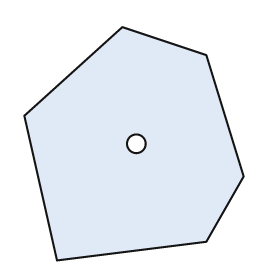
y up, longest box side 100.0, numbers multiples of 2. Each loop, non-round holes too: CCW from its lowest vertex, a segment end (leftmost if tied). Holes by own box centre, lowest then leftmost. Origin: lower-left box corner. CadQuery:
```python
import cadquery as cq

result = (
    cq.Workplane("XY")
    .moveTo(14.0, 0.0)
    .lineTo(78.0, 8.0)
    .lineTo(94.0, 36.0)
    .lineTo(78.0, 88.0)
    .lineTo(42.0, 100.0)
    .lineTo(0.0, 62.0)
    .close()
    .moveTo(48.0, 50.0)
    .circle(4.0)
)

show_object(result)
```